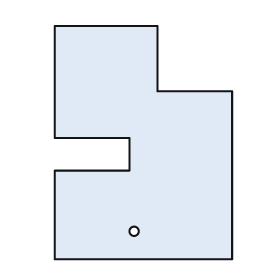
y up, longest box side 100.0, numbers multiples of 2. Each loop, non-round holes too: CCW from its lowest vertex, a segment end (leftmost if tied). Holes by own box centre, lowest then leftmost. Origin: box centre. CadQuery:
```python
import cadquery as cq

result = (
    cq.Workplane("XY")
    .moveTo(-38.0, -50.0)
    .lineTo(38.0, -50.0)
    .lineTo(38.0, 22.0)
    .lineTo(6.0, 22.0)
    .lineTo(6.0, 50.0)
    .lineTo(-38.0, 50.0)
    .lineTo(-38.0, 2.0)
    .lineTo(-6.0, 2.0)
    .lineTo(-6.0, -12.0)
    .lineTo(-38.0, -12.0)
    .close()
    .moveTo(-4.0, -38.0)
    .circle(2.0)
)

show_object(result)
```